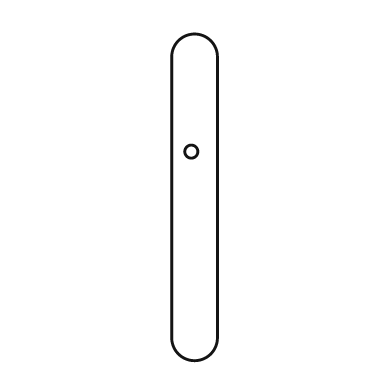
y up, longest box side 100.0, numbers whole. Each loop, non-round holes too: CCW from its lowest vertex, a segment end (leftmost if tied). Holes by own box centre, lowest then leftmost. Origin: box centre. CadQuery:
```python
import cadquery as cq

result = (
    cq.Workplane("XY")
    .moveTo(-7.0, -43.0)
    .threePointArc((0.0, -50.0), (7.0, -43.0))
    .lineTo(7.0, 43.0)
    .threePointArc((0.0, 50.0), (-7.0, 43.0))
    .close()
    .moveTo(-1.0, 14.0)
    .circle(2.0)
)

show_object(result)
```